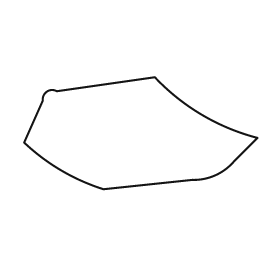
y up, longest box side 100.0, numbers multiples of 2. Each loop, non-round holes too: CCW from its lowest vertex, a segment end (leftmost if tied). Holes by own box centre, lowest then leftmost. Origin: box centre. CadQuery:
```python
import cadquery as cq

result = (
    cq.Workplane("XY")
    .moveTo(-16.0, -24.0)
    .lineTo(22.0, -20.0)
    .threePointArc((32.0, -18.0), (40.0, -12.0))
    .lineTo(50.0, -2.0)
    .threePointArc((26.0, 8.0), (6.0, 24.0))
    .lineTo(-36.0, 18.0)
    .threePointArc((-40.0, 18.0), (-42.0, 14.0))
    .lineTo(-50.0, -4.0)
    .threePointArc((-34.0, -16.0), (-16.0, -24.0))
    .close()
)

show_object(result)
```